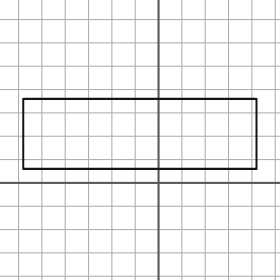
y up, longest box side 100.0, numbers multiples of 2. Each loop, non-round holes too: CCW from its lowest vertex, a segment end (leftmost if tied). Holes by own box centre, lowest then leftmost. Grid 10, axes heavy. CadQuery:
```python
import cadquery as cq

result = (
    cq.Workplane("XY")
    .moveTo(-58.0, 6.0)
    .lineTo(42.0, 6.0)
    .lineTo(42.0, 36.0)
    .lineTo(-58.0, 36.0)
    .close()
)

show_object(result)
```